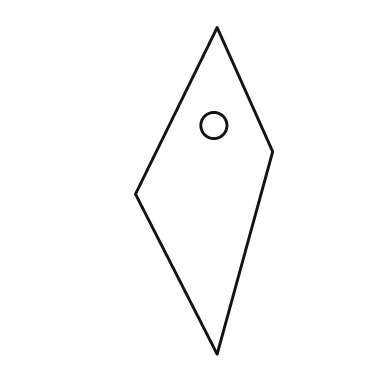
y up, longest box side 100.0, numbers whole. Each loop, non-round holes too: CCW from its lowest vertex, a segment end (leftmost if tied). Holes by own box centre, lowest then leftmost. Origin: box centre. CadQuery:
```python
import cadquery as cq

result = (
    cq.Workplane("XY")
    .moveTo(4.0, -50.0)
    .lineTo(21.0, 12.0)
    .lineTo(4.0, 50.0)
    .lineTo(-21.0, -1.0)
    .close()
    .moveTo(3.0, 20.0)
    .circle(4.0)
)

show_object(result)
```